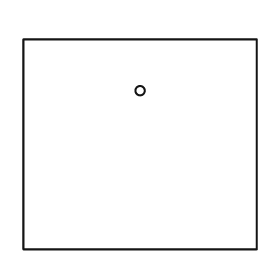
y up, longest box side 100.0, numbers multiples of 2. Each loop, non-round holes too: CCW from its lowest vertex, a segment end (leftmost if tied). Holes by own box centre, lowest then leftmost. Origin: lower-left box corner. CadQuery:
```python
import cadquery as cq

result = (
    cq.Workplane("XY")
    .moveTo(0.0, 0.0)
    .lineTo(100.0, 0.0)
    .lineTo(100.0, 90.0)
    .lineTo(0.0, 90.0)
    .close()
    .moveTo(50.0, 68.0)
    .circle(2.0)
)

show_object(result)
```